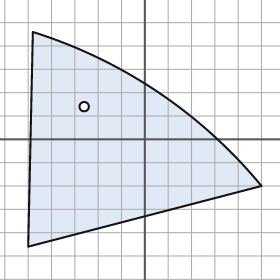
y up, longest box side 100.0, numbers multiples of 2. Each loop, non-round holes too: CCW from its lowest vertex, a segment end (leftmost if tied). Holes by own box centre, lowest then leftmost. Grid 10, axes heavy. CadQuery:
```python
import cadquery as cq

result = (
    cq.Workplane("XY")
    .moveTo(-50.0, -46.0)
    .lineTo(50.0, -20.0)
    .threePointArc((6.0, 20.0), (-48.0, 46.0))
    .close()
    .moveTo(-26.0, 14.0)
    .circle(2.0)
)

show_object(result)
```